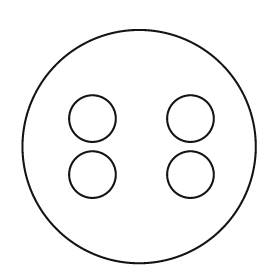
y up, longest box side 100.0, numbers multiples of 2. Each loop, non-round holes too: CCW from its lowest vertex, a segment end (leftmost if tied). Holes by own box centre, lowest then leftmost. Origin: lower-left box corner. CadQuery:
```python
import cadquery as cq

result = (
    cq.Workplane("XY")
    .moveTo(50.0, 50.0)
    .circle(50.0)
    .moveTo(30.0, 38.0)
    .circle(10.0)
    .moveTo(72.0, 38.0)
    .circle(10.0)
    .moveTo(30.0, 62.0)
    .circle(10.0)
    .moveTo(72.0, 62.0)
    .circle(10.0)
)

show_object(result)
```